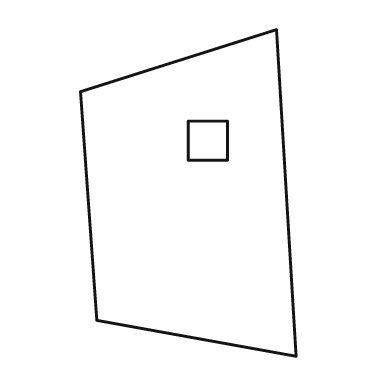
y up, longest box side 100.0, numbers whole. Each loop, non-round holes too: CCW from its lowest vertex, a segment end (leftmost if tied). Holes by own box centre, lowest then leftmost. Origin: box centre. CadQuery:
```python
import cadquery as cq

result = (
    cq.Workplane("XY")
    .moveTo(33.0, -50.0)
    .lineTo(27.0, 50.0)
    .lineTo(-33.0, 31.0)
    .lineTo(-28.0, -39.0)
    .close()
    .moveTo(0.0, 10.0)
    .lineTo(12.0, 10.0)
    .lineTo(12.0, 22.0)
    .lineTo(0.0, 22.0)
    .close()
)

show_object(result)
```